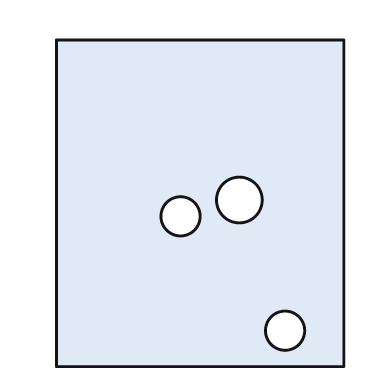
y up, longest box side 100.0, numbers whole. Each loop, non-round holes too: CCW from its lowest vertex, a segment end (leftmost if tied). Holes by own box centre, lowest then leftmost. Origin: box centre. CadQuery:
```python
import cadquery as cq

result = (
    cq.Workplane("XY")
    .moveTo(-44.0, -50.0)
    .lineTo(44.0, -50.0)
    .lineTo(44.0, 50.0)
    .lineTo(-44.0, 50.0)
    .close()
    .moveTo(26.0, -39.0)
    .circle(6.0)
    .moveTo(-6.0, -4.0)
    .circle(6.0)
    .moveTo(12.0, 1.0)
    .circle(7.0)
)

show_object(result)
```